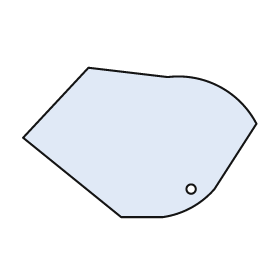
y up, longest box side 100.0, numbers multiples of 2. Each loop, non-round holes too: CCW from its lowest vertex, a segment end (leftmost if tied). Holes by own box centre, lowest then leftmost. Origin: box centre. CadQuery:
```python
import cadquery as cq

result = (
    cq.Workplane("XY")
    .moveTo(-8.0, -32.0)
    .lineTo(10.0, -32.0)
    .threePointArc((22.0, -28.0), (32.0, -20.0))
    .lineTo(50.0, 8.0)
    .threePointArc((34.0, 24.0), (12.0, 28.0))
    .lineTo(-22.0, 32.0)
    .lineTo(-50.0, 2.0)
    .close()
    .moveTo(22.0, -20.0)
    .circle(2.0)
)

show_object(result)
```